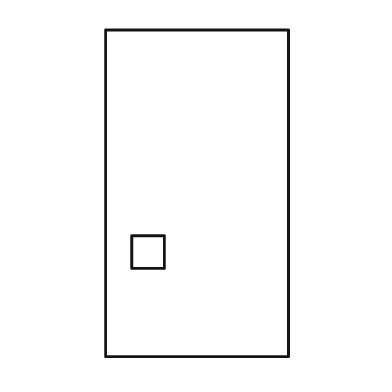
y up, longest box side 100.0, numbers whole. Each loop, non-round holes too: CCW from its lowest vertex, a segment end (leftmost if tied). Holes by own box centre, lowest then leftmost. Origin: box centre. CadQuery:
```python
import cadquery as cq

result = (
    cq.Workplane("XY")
    .moveTo(-28.0, -50.0)
    .lineTo(28.0, -50.0)
    .lineTo(28.0, 50.0)
    .lineTo(-28.0, 50.0)
    .close()
    .moveTo(-20.0, -23.0)
    .lineTo(-10.0, -23.0)
    .lineTo(-10.0, -13.0)
    .lineTo(-20.0, -13.0)
    .close()
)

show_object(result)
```